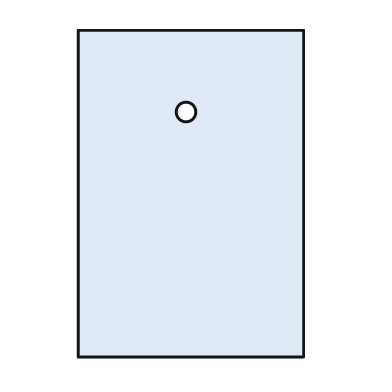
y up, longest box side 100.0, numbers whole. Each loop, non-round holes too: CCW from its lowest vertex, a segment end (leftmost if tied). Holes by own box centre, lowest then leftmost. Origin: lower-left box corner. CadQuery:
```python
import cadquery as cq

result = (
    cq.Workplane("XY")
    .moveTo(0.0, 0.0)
    .lineTo(69.0, 0.0)
    .lineTo(69.0, 100.0)
    .lineTo(0.0, 100.0)
    .close()
    .moveTo(33.0, 75.0)
    .circle(3.0)
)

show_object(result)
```